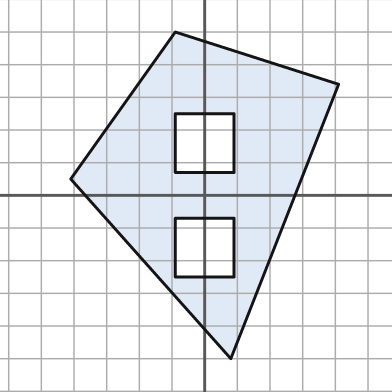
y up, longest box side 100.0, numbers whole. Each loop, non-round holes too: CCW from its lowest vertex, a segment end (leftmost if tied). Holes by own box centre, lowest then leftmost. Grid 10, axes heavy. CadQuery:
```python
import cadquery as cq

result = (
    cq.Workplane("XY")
    .moveTo(8.0, -50.0)
    .lineTo(41.0, 34.0)
    .lineTo(-9.0, 50.0)
    .lineTo(-41.0, 5.0)
    .close()
    .moveTo(-9.0, -25.0)
    .lineTo(9.0, -25.0)
    .lineTo(9.0, -7.0)
    .lineTo(-9.0, -7.0)
    .close()
    .moveTo(-9.0, 7.0)
    .lineTo(9.0, 7.0)
    .lineTo(9.0, 25.0)
    .lineTo(-9.0, 25.0)
    .close()
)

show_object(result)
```